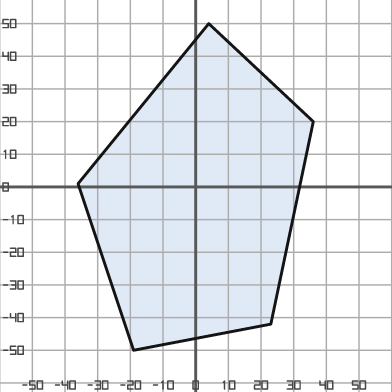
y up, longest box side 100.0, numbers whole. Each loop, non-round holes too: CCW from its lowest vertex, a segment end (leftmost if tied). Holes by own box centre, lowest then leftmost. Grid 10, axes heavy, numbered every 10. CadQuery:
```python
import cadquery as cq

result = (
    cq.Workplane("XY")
    .moveTo(-19.0, -50.0)
    .lineTo(23.0, -42.0)
    .lineTo(36.0, 20.0)
    .lineTo(4.0, 50.0)
    .lineTo(-36.0, 1.0)
    .close()
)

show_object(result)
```